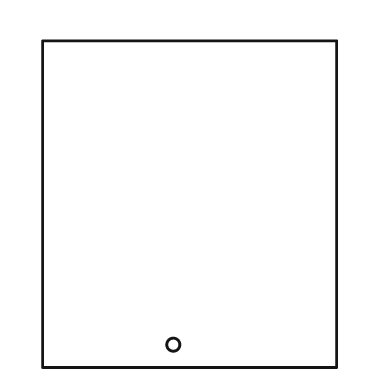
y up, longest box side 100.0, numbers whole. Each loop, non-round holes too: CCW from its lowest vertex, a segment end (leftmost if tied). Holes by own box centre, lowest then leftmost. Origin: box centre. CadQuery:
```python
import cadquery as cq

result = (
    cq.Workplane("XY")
    .moveTo(-45.0, -50.0)
    .lineTo(45.0, -50.0)
    .lineTo(45.0, 50.0)
    .lineTo(-45.0, 50.0)
    .close()
    .moveTo(-5.0, -43.0)
    .circle(2.0)
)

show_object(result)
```